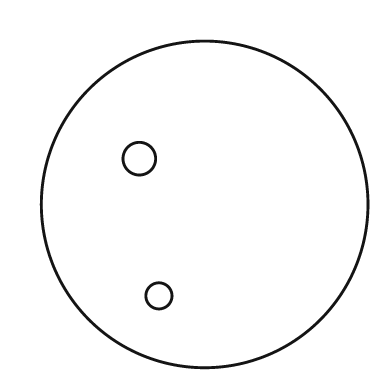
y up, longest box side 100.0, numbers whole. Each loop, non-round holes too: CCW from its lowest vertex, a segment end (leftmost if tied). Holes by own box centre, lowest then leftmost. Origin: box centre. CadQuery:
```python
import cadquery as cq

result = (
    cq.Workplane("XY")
    .moveTo(0.0, 0.0)
    .circle(50.0)
    .moveTo(-14.0, -28.0)
    .circle(4.0)
    .moveTo(-20.0, 14.0)
    .circle(5.0)
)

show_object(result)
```